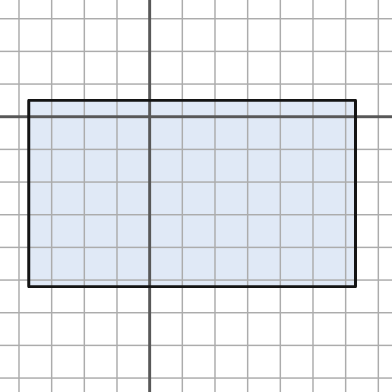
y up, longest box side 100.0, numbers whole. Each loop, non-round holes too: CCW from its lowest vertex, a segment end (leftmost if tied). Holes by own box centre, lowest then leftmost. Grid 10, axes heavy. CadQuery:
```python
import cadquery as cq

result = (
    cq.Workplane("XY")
    .moveTo(-37.0, -52.0)
    .lineTo(63.0, -52.0)
    .lineTo(63.0, 5.0)
    .lineTo(-37.0, 5.0)
    .close()
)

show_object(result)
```